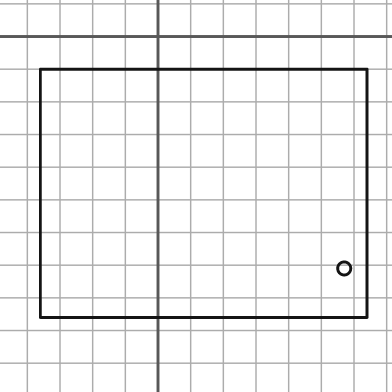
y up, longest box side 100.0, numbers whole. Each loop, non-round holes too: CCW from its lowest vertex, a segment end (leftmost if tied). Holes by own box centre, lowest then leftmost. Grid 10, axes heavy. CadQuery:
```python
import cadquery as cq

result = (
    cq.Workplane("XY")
    .moveTo(-36.0, -86.0)
    .lineTo(64.0, -86.0)
    .lineTo(64.0, -10.0)
    .lineTo(-36.0, -10.0)
    .close()
    .moveTo(57.0, -71.0)
    .circle(2.0)
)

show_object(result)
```